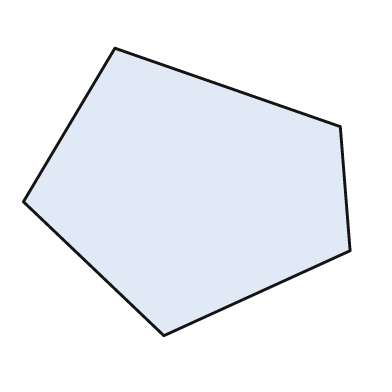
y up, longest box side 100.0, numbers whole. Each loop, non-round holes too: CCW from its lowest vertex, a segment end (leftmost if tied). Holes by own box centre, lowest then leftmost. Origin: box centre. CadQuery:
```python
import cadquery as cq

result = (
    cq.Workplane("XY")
    .moveTo(-7.0, -44.0)
    .lineTo(50.0, -18.0)
    .lineTo(47.0, 20.0)
    .lineTo(-22.0, 44.0)
    .lineTo(-50.0, -3.0)
    .close()
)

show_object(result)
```